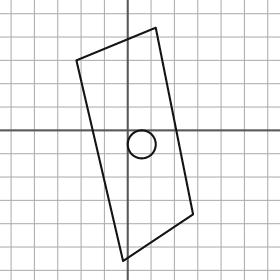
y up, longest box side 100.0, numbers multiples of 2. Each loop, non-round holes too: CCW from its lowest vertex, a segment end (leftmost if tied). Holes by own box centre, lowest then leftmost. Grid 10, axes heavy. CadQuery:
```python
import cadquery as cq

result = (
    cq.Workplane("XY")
    .moveTo(-2.0, -56.0)
    .lineTo(28.0, -36.0)
    .lineTo(12.0, 44.0)
    .lineTo(-22.0, 30.0)
    .close()
    .moveTo(6.0, -6.0)
    .circle(6.0)
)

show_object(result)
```